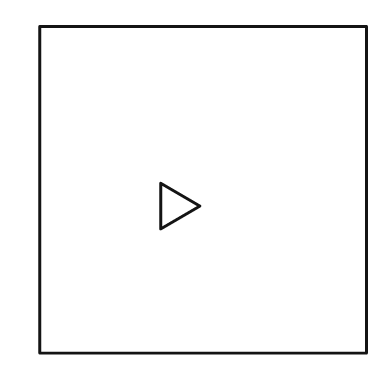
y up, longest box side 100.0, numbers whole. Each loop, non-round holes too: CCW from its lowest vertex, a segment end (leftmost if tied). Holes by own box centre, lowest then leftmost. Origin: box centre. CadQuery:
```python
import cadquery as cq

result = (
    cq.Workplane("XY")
    .moveTo(-50.0, -50.0)
    .lineTo(50.0, -50.0)
    .lineTo(50.0, 50.0)
    .lineTo(-50.0, 50.0)
    .close()
    .moveTo(-13.0, -12.0)
    .lineTo(-1.0, -5.0)
    .lineTo(-13.0, 2.0)
    .close()
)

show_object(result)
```